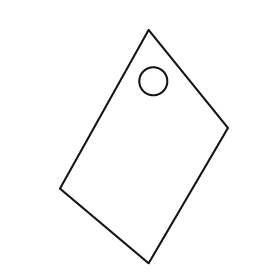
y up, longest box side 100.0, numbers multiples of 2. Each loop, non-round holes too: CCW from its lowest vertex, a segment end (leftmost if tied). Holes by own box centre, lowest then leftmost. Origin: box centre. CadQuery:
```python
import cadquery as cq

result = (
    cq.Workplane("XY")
    .moveTo(2.0, -50.0)
    .lineTo(36.0, 8.0)
    .lineTo(2.0, 50.0)
    .lineTo(-36.0, -18.0)
    .close()
    .moveTo(4.0, 28.0)
    .circle(6.0)
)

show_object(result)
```